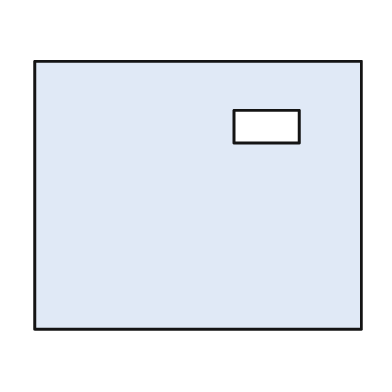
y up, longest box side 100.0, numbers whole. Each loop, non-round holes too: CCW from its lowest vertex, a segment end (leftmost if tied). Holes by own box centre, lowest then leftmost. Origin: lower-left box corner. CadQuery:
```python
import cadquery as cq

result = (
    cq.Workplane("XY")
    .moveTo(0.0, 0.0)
    .lineTo(100.0, 0.0)
    .lineTo(100.0, 82.0)
    .lineTo(0.0, 82.0)
    .close()
    .moveTo(61.0, 57.0)
    .lineTo(81.0, 57.0)
    .lineTo(81.0, 67.0)
    .lineTo(61.0, 67.0)
    .close()
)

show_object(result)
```